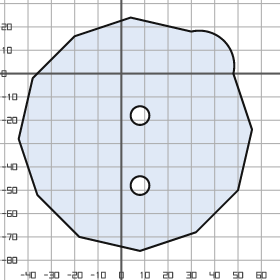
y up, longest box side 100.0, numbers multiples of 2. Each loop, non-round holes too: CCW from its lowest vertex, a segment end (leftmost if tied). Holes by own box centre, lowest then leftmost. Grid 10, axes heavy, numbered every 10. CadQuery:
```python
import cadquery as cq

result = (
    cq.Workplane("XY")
    .moveTo(8.0, -76.0)
    .lineTo(32.0, -68.0)
    .lineTo(50.0, -50.0)
    .lineTo(56.0, -24.0)
    .lineTo(48.0, 0.0)
    .threePointArc((44.0, 14.0), (30.0, 18.0))
    .lineTo(4.0, 24.0)
    .lineTo(-20.0, 16.0)
    .lineTo(-38.0, -2.0)
    .lineTo(-44.0, -28.0)
    .lineTo(-36.0, -52.0)
    .lineTo(-18.0, -70.0)
    .close()
    .moveTo(8.0, -48.0)
    .circle(4.0)
    .moveTo(8.0, -18.0)
    .circle(4.0)
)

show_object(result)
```